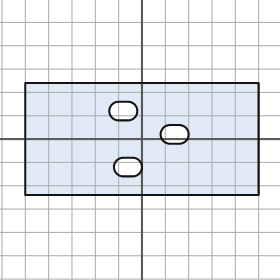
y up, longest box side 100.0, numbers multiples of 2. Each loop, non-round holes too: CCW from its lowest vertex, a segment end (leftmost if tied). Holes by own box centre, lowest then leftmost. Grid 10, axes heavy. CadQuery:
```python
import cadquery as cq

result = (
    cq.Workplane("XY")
    .moveTo(-50.0, -24.0)
    .lineTo(50.0, -24.0)
    .lineTo(50.0, 24.0)
    .lineTo(-50.0, 24.0)
    .close()
    .moveTo(-8.0, -16.0)
    .lineTo(-4.0, -16.0)
    .threePointArc((0.0, -12.0), (-4.0, -8.0))
    .lineTo(-8.0, -8.0)
    .threePointArc((-12.0, -12.0), (-8.0, -16.0))
    .close()
    .moveTo(12.0, -2.0)
    .lineTo(16.0, -2.0)
    .threePointArc((20.0, 2.0), (16.0, 6.0))
    .lineTo(12.0, 6.0)
    .threePointArc((8.0, 2.0), (12.0, -2.0))
    .close()
    .moveTo(-10.0, 8.0)
    .lineTo(-6.0, 8.0)
    .threePointArc((-2.0, 12.0), (-6.0, 16.0))
    .lineTo(-10.0, 16.0)
    .threePointArc((-14.0, 12.0), (-10.0, 8.0))
    .close()
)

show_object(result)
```